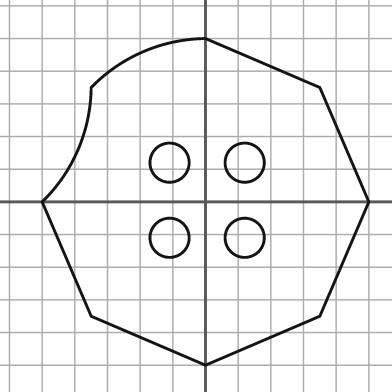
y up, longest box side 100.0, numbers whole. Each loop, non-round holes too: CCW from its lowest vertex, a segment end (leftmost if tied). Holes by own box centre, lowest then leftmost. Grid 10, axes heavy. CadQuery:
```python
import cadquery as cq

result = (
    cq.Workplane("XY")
    .moveTo(0.0, -50.0)
    .lineTo(35.0, -35.0)
    .lineTo(50.0, 0.0)
    .lineTo(35.0, 35.0)
    .lineTo(0.0, 50.0)
    .threePointArc((-19.0, 46.0), (-35.0, 35.0))
    .threePointArc((-39.0, 16.0), (-50.0, 0.0))
    .lineTo(-35.0, -35.0)
    .close()
    .moveTo(-11.0, -11.0)
    .circle(6.0)
    .moveTo(12.0, -11.0)
    .circle(6.0)
    .moveTo(-11.0, 12.0)
    .circle(6.0)
    .moveTo(12.0, 12.0)
    .circle(6.0)
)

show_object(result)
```